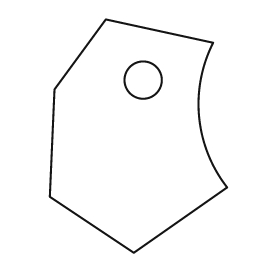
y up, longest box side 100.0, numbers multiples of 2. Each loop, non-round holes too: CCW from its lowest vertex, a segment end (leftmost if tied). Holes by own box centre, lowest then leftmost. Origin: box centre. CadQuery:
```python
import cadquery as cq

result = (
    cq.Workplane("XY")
    .moveTo(-2.0, -50.0)
    .lineTo(38.0, -22.0)
    .threePointArc((26.0, 8.0), (32.0, 40.0))
    .lineTo(-14.0, 50.0)
    .lineTo(-36.0, 20.0)
    .lineTo(-38.0, -26.0)
    .close()
    .moveTo(2.0, 24.0)
    .circle(8.0)
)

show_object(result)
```